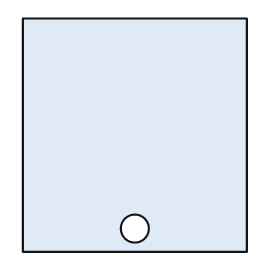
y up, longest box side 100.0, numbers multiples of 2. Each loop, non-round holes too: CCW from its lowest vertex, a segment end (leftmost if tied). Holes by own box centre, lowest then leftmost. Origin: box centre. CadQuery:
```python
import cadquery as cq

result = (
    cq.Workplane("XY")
    .moveTo(-48.0, -50.0)
    .lineTo(48.0, -50.0)
    .lineTo(48.0, 50.0)
    .lineTo(-48.0, 50.0)
    .close()
    .moveTo(0.0, -40.0)
    .circle(6.0)
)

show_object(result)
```